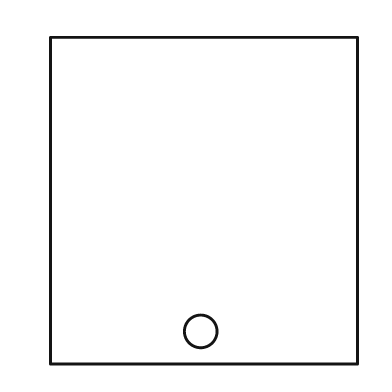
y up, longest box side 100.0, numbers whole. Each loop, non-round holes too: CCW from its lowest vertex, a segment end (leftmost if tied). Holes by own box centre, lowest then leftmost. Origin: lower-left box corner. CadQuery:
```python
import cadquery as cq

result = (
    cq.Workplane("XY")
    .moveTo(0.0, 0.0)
    .lineTo(94.0, 0.0)
    .lineTo(94.0, 100.0)
    .lineTo(0.0, 100.0)
    .close()
    .moveTo(46.0, 10.0)
    .circle(5.0)
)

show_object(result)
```